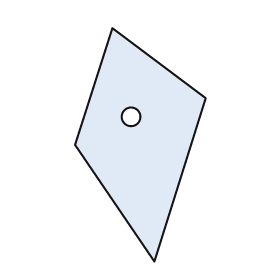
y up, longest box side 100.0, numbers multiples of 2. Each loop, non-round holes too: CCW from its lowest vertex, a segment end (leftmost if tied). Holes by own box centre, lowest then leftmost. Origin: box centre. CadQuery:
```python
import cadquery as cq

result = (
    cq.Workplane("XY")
    .moveTo(6.0, -50.0)
    .lineTo(28.0, 20.0)
    .lineTo(-12.0, 50.0)
    .lineTo(-28.0, 0.0)
    .close()
    .moveTo(-4.0, 12.0)
    .circle(4.0)
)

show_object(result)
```